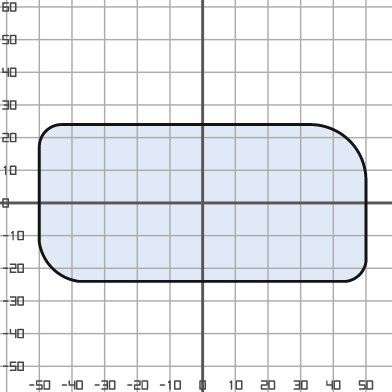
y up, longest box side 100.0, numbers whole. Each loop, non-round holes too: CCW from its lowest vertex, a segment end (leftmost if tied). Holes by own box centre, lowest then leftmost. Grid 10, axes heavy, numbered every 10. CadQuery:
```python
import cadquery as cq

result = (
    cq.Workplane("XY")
    .moveTo(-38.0, -24.0)
    .lineTo(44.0, -24.0)
    .threePointArc((48.0, -22.0), (50.0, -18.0))
    .lineTo(50.0, 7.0)
    .threePointArc((45.0, 19.0), (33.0, 24.0))
    .lineTo(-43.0, 24.0)
    .threePointArc((-48.0, 22.0), (-50.0, 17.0))
    .lineTo(-50.0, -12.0)
    .threePointArc((-46.0, -20.0), (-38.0, -24.0))
    .close()
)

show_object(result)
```